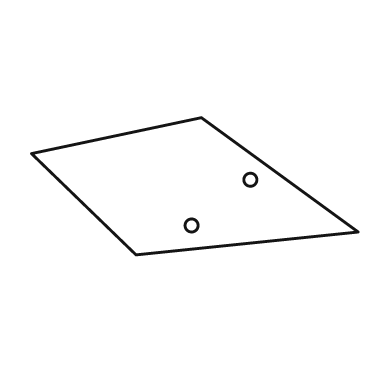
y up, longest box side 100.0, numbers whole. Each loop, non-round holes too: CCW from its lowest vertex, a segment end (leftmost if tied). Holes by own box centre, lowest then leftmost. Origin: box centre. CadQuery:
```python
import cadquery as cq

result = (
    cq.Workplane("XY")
    .moveTo(-18.0, -21.0)
    .lineTo(50.0, -14.0)
    .lineTo(2.0, 21.0)
    .lineTo(-50.0, 10.0)
    .close()
    .moveTo(-1.0, -12.0)
    .circle(2.0)
    .moveTo(17.0, 2.0)
    .circle(2.0)
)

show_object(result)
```